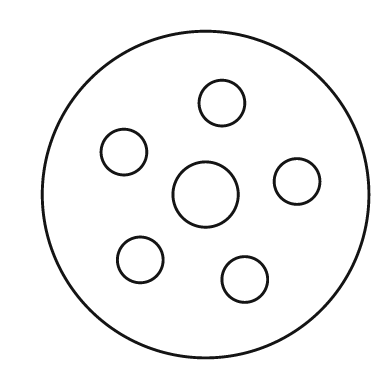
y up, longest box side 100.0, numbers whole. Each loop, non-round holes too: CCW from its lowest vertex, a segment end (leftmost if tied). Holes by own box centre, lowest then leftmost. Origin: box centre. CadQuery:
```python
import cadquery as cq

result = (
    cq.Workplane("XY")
    .moveTo(0.0, 0.0)
    .circle(50.0)
    .moveTo(12.0, -26.0)
    .circle(7.0)
    .moveTo(-20.0, -20.0)
    .circle(7.0)
    .moveTo(0.0, 0.0)
    .circle(10.0)
    .moveTo(28.0, 4.0)
    .circle(7.0)
    .moveTo(-25.0, 13.0)
    .circle(7.0)
    .moveTo(5.0, 28.0)
    .circle(7.0)
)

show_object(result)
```